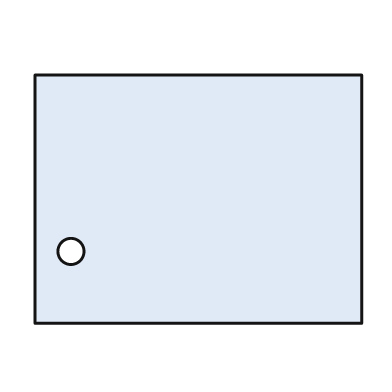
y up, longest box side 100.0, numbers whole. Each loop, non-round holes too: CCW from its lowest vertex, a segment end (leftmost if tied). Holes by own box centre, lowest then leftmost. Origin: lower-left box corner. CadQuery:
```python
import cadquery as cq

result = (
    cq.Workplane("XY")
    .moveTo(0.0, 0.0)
    .lineTo(100.0, 0.0)
    .lineTo(100.0, 76.0)
    .lineTo(0.0, 76.0)
    .close()
    .moveTo(11.0, 22.0)
    .circle(4.0)
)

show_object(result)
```